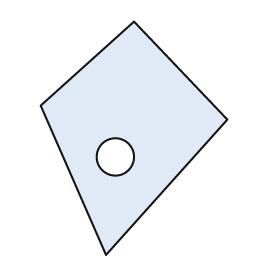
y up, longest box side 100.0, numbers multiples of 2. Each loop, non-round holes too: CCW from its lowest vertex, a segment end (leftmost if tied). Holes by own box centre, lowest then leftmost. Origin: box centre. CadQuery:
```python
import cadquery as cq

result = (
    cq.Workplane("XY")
    .moveTo(-12.0, -50.0)
    .lineTo(40.0, 8.0)
    .lineTo(0.0, 50.0)
    .lineTo(-40.0, 14.0)
    .close()
    .moveTo(-8.0, -8.0)
    .circle(8.0)
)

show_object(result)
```